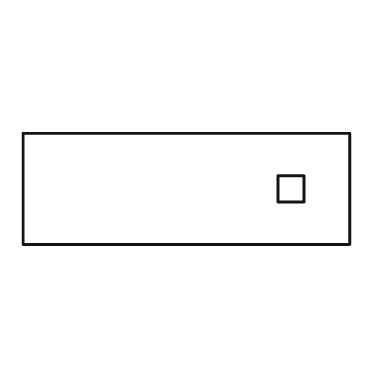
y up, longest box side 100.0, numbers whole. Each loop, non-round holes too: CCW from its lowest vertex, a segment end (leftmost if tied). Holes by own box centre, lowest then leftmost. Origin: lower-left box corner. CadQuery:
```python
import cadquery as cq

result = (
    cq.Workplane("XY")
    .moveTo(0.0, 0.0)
    .lineTo(100.0, 0.0)
    .lineTo(100.0, 34.0)
    .lineTo(0.0, 34.0)
    .close()
    .moveTo(78.0, 13.0)
    .lineTo(86.0, 13.0)
    .lineTo(86.0, 21.0)
    .lineTo(78.0, 21.0)
    .close()
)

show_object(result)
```